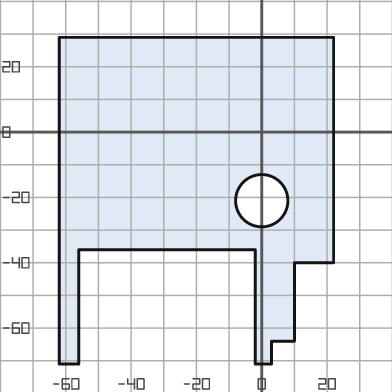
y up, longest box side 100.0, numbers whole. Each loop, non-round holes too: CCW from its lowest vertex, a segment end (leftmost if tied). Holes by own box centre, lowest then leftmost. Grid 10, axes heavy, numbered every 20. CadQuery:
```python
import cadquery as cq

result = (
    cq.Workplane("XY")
    .moveTo(-62.0, -71.0)
    .lineTo(-56.0, -71.0)
    .lineTo(-56.0, -36.0)
    .lineTo(-2.0, -36.0)
    .lineTo(-2.0, -71.0)
    .lineTo(3.0, -71.0)
    .lineTo(3.0, -64.0)
    .lineTo(10.0, -64.0)
    .lineTo(10.0, -40.0)
    .lineTo(22.0, -40.0)
    .lineTo(22.0, 29.0)
    .lineTo(-62.0, 29.0)
    .close()
    .moveTo(0.0, -21.0)
    .circle(8.0)
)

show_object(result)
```